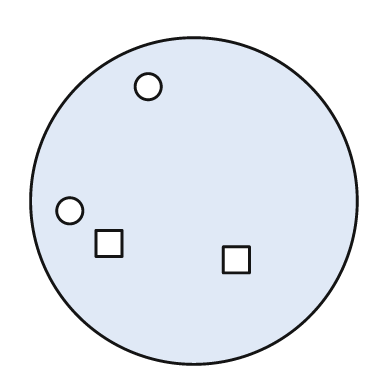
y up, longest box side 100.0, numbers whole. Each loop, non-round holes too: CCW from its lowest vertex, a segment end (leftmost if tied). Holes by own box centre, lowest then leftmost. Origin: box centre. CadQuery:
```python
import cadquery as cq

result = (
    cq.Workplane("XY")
    .moveTo(0.0, 0.0)
    .circle(50.0)
    .moveTo(9.0, -22.0)
    .lineTo(17.0, -22.0)
    .lineTo(17.0, -14.0)
    .lineTo(9.0, -14.0)
    .close()
    .moveTo(-30.0, -17.0)
    .lineTo(-22.0, -17.0)
    .lineTo(-22.0, -9.0)
    .lineTo(-30.0, -9.0)
    .close()
    .moveTo(-38.0, -3.0)
    .circle(4.0)
    .moveTo(-14.0, 35.0)
    .circle(4.0)
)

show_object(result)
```